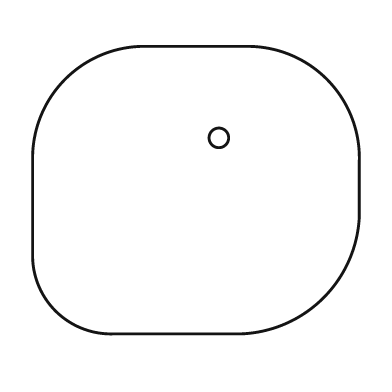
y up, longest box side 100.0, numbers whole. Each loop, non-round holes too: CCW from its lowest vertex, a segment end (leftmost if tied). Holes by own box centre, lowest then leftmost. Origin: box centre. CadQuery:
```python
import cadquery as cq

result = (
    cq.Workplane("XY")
    .moveTo(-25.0, -44.0)
    .lineTo(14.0, -44.0)
    .threePointArc((39.0, -33.0), (50.0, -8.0))
    .lineTo(50.0, 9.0)
    .threePointArc((40.0, 34.0), (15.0, 44.0))
    .lineTo(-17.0, 44.0)
    .threePointArc((-40.0, 34.0), (-50.0, 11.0))
    .lineTo(-50.0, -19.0)
    .threePointArc((-43.0, -37.0), (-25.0, -44.0))
    .close()
    .moveTo(7.0, 16.0)
    .circle(3.0)
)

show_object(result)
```